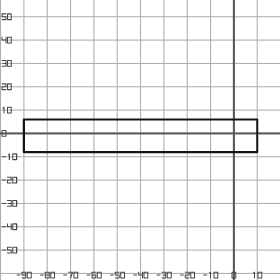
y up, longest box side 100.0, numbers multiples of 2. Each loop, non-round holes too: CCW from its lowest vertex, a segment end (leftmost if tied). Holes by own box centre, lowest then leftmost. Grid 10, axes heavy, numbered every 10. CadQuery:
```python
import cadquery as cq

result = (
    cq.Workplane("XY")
    .moveTo(-90.0, -8.0)
    .lineTo(10.0, -8.0)
    .lineTo(10.0, 6.0)
    .lineTo(-90.0, 6.0)
    .close()
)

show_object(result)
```